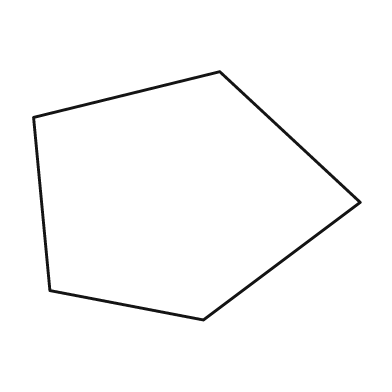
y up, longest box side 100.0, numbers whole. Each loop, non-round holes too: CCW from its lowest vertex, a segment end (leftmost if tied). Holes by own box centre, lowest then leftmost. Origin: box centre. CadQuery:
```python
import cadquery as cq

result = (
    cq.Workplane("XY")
    .moveTo(2.0, -38.0)
    .lineTo(50.0, -2.0)
    .lineTo(7.0, 38.0)
    .lineTo(-50.0, 24.0)
    .lineTo(-45.0, -29.0)
    .close()
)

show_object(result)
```